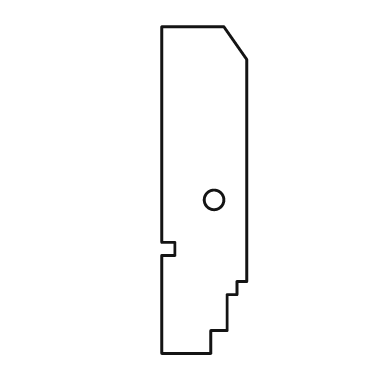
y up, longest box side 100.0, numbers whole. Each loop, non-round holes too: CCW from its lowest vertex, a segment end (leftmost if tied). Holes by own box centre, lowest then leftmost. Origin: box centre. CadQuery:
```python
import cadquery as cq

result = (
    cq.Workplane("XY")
    .moveTo(-13.0, -50.0)
    .lineTo(2.0, -50.0)
    .lineTo(2.0, -43.0)
    .lineTo(7.0, -43.0)
    .lineTo(7.0, -32.0)
    .lineTo(10.0, -32.0)
    .lineTo(10.0, -28.0)
    .lineTo(13.0, -28.0)
    .lineTo(13.0, 40.0)
    .lineTo(6.0, 50.0)
    .lineTo(-13.0, 50.0)
    .lineTo(-13.0, -16.0)
    .lineTo(-9.0, -16.0)
    .lineTo(-9.0, -20.0)
    .lineTo(-13.0, -20.0)
    .close()
    .moveTo(3.0, -3.0)
    .circle(3.0)
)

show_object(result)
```